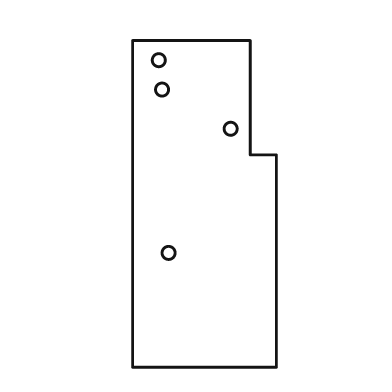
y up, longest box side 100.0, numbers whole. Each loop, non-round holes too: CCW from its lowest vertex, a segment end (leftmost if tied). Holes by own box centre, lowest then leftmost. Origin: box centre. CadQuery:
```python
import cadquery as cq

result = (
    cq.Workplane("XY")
    .moveTo(-22.0, -50.0)
    .lineTo(22.0, -50.0)
    .lineTo(22.0, 15.0)
    .lineTo(14.0, 15.0)
    .lineTo(14.0, 50.0)
    .lineTo(-22.0, 50.0)
    .close()
    .moveTo(-11.0, -15.0)
    .circle(2.0)
    .moveTo(8.0, 23.0)
    .circle(2.0)
    .moveTo(-13.0, 35.0)
    .circle(2.0)
    .moveTo(-14.0, 44.0)
    .circle(2.0)
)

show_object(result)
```